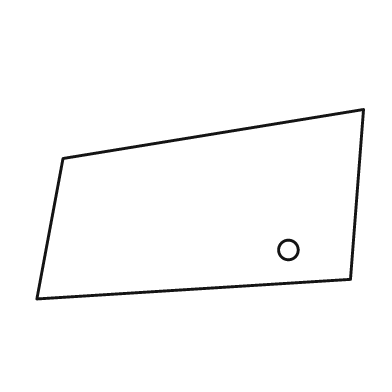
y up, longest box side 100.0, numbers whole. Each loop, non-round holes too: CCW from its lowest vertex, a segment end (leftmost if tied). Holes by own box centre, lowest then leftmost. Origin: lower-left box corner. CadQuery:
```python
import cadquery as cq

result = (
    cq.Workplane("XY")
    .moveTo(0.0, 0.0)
    .lineTo(96.0, 6.0)
    .lineTo(100.0, 58.0)
    .lineTo(8.0, 43.0)
    .close()
    .moveTo(77.0, 15.0)
    .circle(3.0)
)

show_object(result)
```